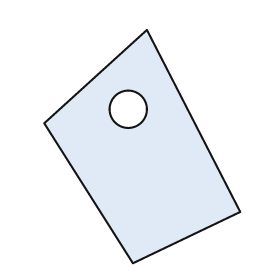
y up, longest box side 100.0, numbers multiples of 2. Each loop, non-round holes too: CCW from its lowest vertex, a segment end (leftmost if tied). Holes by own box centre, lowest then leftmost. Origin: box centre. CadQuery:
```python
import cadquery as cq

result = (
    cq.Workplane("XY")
    .moveTo(-4.0, -50.0)
    .lineTo(42.0, -28.0)
    .lineTo(2.0, 50.0)
    .lineTo(-42.0, 10.0)
    .close()
    .moveTo(-6.0, 16.0)
    .circle(8.0)
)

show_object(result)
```